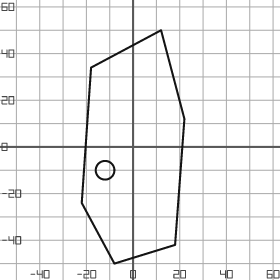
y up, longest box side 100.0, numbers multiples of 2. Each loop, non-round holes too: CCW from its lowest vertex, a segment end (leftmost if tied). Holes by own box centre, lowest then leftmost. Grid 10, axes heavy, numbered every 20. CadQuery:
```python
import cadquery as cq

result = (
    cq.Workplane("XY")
    .moveTo(-8.0, -50.0)
    .lineTo(18.0, -42.0)
    .lineTo(22.0, 12.0)
    .lineTo(12.0, 50.0)
    .lineTo(-18.0, 34.0)
    .lineTo(-22.0, -24.0)
    .close()
    .moveTo(-12.0, -10.0)
    .circle(4.0)
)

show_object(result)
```